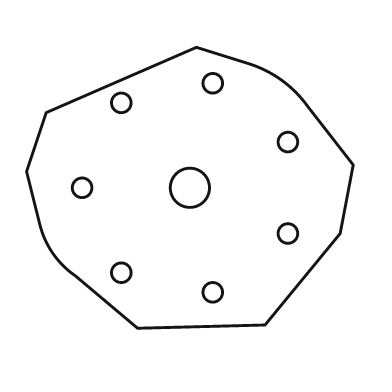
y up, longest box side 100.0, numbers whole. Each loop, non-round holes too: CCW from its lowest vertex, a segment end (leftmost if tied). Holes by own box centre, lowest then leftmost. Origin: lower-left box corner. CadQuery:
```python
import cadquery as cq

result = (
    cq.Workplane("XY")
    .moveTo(34.0, 0.0)
    .lineTo(73.0, 1.0)
    .lineTo(96.0, 29.0)
    .lineTo(100.0, 50.0)
    .lineTo(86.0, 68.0)
    .threePointArc((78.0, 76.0), (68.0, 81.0))
    .lineTo(52.0, 86.0)
    .lineTo(6.0, 66.0)
    .lineTo(0.0, 48.0)
    .lineTo(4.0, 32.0)
    .threePointArc((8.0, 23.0), (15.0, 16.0))
    .close()
    .moveTo(57.0, 11.0)
    .circle(3.0)
    .moveTo(29.0, 17.0)
    .circle(3.0)
    .moveTo(80.0, 29.0)
    .circle(3.0)
    .moveTo(17.0, 43.0)
    .circle(3.0)
    .moveTo(50.0, 43.0)
    .circle(6.0)
    .moveTo(80.0, 57.0)
    .circle(3.0)
    .moveTo(29.0, 69.0)
    .circle(3.0)
    .moveTo(57.0, 75.0)
    .circle(3.0)
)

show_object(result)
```